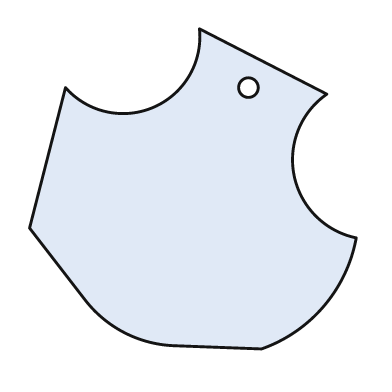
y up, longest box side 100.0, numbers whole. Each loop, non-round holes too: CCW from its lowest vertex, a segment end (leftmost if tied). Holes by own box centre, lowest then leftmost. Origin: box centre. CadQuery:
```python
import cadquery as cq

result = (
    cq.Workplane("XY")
    .moveTo(21.0, -49.0)
    .threePointArc((40.0, -36.0), (50.0, -15.0))
    .threePointArc((31.0, 4.0), (41.0, 29.0))
    .lineTo(2.0, 49.0)
    .threePointArc((-12.0, 25.0), (-39.0, 31.0))
    .lineTo(-50.0, -12.0)
    .lineTo(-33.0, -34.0)
    .threePointArc((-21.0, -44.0), (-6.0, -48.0))
    .close()
    .moveTo(17.0, 31.0)
    .circle(3.0)
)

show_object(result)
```